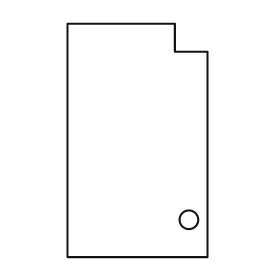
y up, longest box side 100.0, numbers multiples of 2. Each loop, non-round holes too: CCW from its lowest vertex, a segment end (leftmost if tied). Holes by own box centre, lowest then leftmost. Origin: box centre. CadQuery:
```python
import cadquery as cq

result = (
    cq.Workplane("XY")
    .moveTo(-30.0, -50.0)
    .lineTo(30.0, -50.0)
    .lineTo(30.0, 38.0)
    .lineTo(16.0, 38.0)
    .lineTo(16.0, 50.0)
    .lineTo(-30.0, 50.0)
    .close()
    .moveTo(22.0, -34.0)
    .circle(4.0)
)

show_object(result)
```